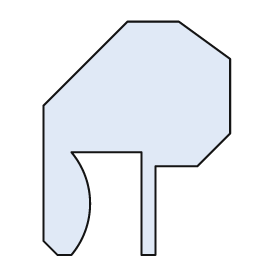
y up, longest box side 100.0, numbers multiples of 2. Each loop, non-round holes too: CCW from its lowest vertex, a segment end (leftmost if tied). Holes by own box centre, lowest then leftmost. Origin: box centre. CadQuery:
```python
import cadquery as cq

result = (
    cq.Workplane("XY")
    .moveTo(-34.0, -50.0)
    .lineTo(-28.0, -50.0)
    .threePointArc((-20.0, -28.0), (-28.0, -6.0))
    .lineTo(2.0, -6.0)
    .lineTo(2.0, -50.0)
    .lineTo(8.0, -50.0)
    .lineTo(8.0, -12.0)
    .lineTo(26.0, -12.0)
    .lineTo(40.0, 2.0)
    .lineTo(40.0, 34.0)
    .lineTo(18.0, 50.0)
    .lineTo(-4.0, 50.0)
    .lineTo(-40.0, 14.0)
    .lineTo(-40.0, -44.0)
    .close()
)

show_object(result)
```